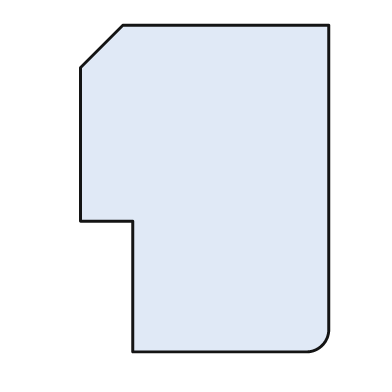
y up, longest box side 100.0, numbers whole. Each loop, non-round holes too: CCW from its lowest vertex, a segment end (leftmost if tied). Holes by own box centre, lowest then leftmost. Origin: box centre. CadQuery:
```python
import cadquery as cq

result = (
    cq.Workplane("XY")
    .moveTo(-22.0, -50.0)
    .lineTo(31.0, -50.0)
    .threePointArc((36.0, -48.0), (38.0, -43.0))
    .lineTo(38.0, 50.0)
    .lineTo(-25.0, 50.0)
    .lineTo(-38.0, 37.0)
    .lineTo(-38.0, -10.0)
    .lineTo(-22.0, -10.0)
    .close()
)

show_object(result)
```